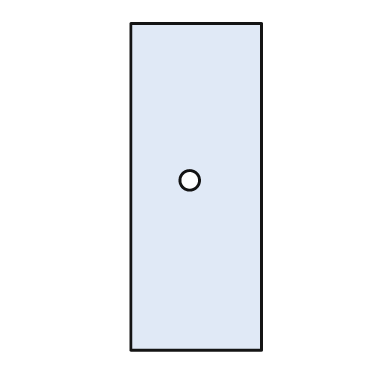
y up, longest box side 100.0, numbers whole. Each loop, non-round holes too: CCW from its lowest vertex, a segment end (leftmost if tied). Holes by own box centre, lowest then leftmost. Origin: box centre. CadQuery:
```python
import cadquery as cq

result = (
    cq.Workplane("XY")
    .moveTo(-20.0, -50.0)
    .lineTo(20.0, -50.0)
    .lineTo(20.0, 50.0)
    .lineTo(-20.0, 50.0)
    .close()
    .moveTo(-2.0, 2.0)
    .circle(3.0)
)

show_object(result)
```